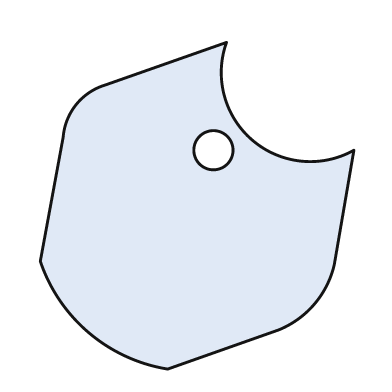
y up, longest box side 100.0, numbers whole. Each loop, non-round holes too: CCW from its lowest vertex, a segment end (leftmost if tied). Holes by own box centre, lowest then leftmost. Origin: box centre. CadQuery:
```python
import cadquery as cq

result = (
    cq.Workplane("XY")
    .moveTo(-9.0, -50.0)
    .lineTo(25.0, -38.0)
    .threePointArc((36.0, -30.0), (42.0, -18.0))
    .lineTo(48.0, 17.0)
    .threePointArc((17.0, 20.0), (9.0, 50.0))
    .lineTo(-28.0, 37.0)
    .threePointArc((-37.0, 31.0), (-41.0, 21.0))
    .lineTo(-48.0, -17.0)
    .threePointArc((-33.0, -39.0), (-9.0, -50.0))
    .close()
    .moveTo(5.0, 17.0)
    .circle(6.0)
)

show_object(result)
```